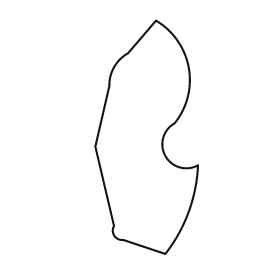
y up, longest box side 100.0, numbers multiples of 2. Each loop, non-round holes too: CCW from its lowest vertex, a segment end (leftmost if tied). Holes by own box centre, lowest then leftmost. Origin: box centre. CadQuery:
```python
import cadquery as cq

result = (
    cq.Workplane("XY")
    .moveTo(8.0, -50.0)
    .threePointArc((18.0, -32.0), (22.0, -12.0))
    .threePointArc((8.0, -8.0), (12.0, 6.0))
    .threePointArc((18.0, 30.0), (4.0, 50.0))
    .lineTo(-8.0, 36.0)
    .threePointArc((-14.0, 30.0), (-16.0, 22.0))
    .lineTo(-22.0, -4.0)
    .lineTo(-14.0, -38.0)
    .threePointArc((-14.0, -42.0), (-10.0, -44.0))
    .close()
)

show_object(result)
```